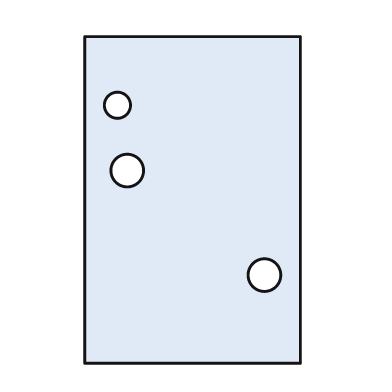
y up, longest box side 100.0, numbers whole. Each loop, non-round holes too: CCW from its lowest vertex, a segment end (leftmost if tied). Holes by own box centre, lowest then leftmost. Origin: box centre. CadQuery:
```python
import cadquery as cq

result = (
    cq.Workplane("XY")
    .moveTo(-33.0, -50.0)
    .lineTo(33.0, -50.0)
    .lineTo(33.0, 50.0)
    .lineTo(-33.0, 50.0)
    .close()
    .moveTo(22.0, -23.0)
    .circle(5.0)
    .moveTo(-20.0, 9.0)
    .circle(5.0)
    .moveTo(-23.0, 29.0)
    .circle(4.0)
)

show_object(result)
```